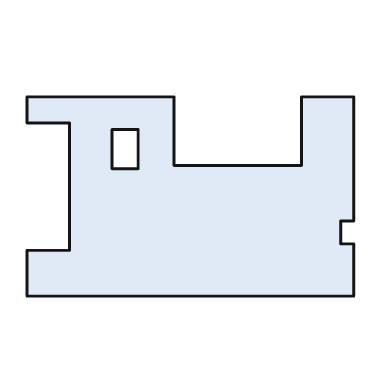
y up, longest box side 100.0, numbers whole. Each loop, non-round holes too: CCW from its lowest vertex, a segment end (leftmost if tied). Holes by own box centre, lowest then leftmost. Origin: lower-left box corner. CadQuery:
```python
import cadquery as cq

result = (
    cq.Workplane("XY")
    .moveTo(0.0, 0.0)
    .lineTo(100.0, 0.0)
    .lineTo(100.0, 16.0)
    .lineTo(96.0, 16.0)
    .lineTo(96.0, 23.0)
    .lineTo(100.0, 23.0)
    .lineTo(100.0, 61.0)
    .lineTo(84.0, 61.0)
    .lineTo(84.0, 40.0)
    .lineTo(45.0, 40.0)
    .lineTo(45.0, 61.0)
    .lineTo(0.0, 61.0)
    .lineTo(0.0, 53.0)
    .lineTo(13.0, 53.0)
    .lineTo(13.0, 14.0)
    .lineTo(0.0, 14.0)
    .close()
    .moveTo(26.0, 39.0)
    .lineTo(34.0, 39.0)
    .lineTo(34.0, 51.0)
    .lineTo(26.0, 51.0)
    .close()
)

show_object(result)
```